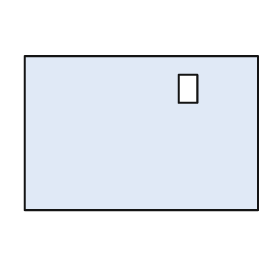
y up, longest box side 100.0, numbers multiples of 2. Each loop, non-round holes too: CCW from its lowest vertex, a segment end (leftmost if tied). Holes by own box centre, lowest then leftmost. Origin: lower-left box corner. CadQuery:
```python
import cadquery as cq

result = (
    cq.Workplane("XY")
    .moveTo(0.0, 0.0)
    .lineTo(100.0, 0.0)
    .lineTo(100.0, 66.0)
    .lineTo(0.0, 66.0)
    .close()
    .moveTo(66.0, 46.0)
    .lineTo(74.0, 46.0)
    .lineTo(74.0, 58.0)
    .lineTo(66.0, 58.0)
    .close()
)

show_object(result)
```